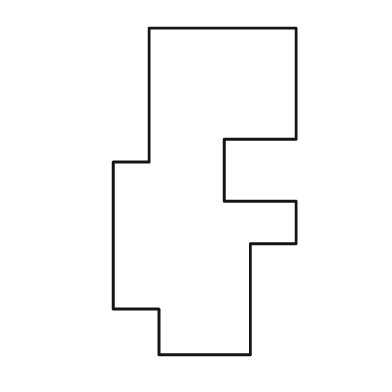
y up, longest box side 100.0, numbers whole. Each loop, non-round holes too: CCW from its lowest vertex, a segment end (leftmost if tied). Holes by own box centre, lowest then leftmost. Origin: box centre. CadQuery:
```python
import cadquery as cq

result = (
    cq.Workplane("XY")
    .moveTo(-14.0, -50.0)
    .lineTo(14.0, -50.0)
    .lineTo(14.0, -16.0)
    .lineTo(28.0, -16.0)
    .lineTo(28.0, -3.0)
    .lineTo(6.0, -3.0)
    .lineTo(6.0, 16.0)
    .lineTo(28.0, 16.0)
    .lineTo(28.0, 50.0)
    .lineTo(-17.0, 50.0)
    .lineTo(-17.0, 9.0)
    .lineTo(-28.0, 9.0)
    .lineTo(-28.0, -36.0)
    .lineTo(-14.0, -36.0)
    .close()
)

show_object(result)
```